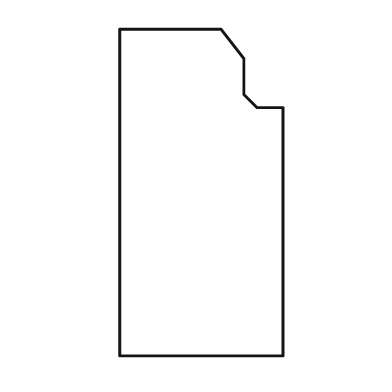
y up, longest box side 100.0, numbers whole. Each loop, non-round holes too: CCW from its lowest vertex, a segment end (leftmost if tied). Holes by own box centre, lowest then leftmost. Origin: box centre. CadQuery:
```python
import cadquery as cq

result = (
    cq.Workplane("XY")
    .moveTo(-25.0, -50.0)
    .lineTo(25.0, -50.0)
    .lineTo(25.0, 26.0)
    .lineTo(17.0, 26.0)
    .lineTo(13.0, 30.0)
    .lineTo(13.0, 41.0)
    .lineTo(6.0, 50.0)
    .lineTo(-25.0, 50.0)
    .close()
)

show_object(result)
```